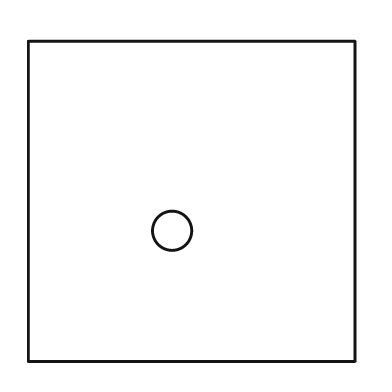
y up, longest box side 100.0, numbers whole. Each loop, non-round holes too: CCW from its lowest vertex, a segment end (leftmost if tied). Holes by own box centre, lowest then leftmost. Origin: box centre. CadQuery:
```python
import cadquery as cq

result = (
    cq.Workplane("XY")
    .moveTo(-50.0, -49.0)
    .lineTo(50.0, -49.0)
    .lineTo(50.0, 49.0)
    .lineTo(-50.0, 49.0)
    .close()
    .moveTo(-6.0, -9.0)
    .circle(6.0)
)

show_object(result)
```